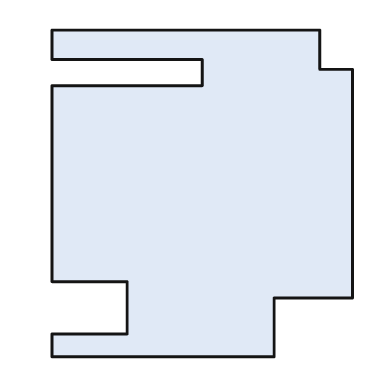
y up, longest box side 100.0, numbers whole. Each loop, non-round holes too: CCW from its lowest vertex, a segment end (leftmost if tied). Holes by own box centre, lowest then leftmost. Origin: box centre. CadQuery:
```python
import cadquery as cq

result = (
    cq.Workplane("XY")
    .moveTo(-46.0, -50.0)
    .lineTo(22.0, -50.0)
    .lineTo(22.0, -32.0)
    .lineTo(46.0, -32.0)
    .lineTo(46.0, 38.0)
    .lineTo(36.0, 38.0)
    .lineTo(36.0, 50.0)
    .lineTo(-46.0, 50.0)
    .lineTo(-46.0, 41.0)
    .lineTo(0.0, 41.0)
    .lineTo(0.0, 33.0)
    .lineTo(-46.0, 33.0)
    .lineTo(-46.0, -27.0)
    .lineTo(-23.0, -27.0)
    .lineTo(-23.0, -43.0)
    .lineTo(-46.0, -43.0)
    .close()
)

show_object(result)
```